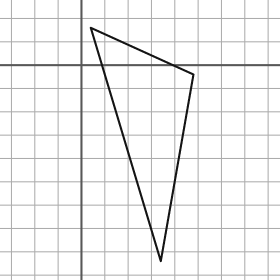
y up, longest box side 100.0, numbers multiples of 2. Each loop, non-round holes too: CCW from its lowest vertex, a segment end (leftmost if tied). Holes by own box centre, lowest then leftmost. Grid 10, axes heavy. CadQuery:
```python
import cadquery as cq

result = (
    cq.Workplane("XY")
    .moveTo(34.0, -84.0)
    .lineTo(48.0, -4.0)
    .lineTo(4.0, 16.0)
    .close()
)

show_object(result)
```